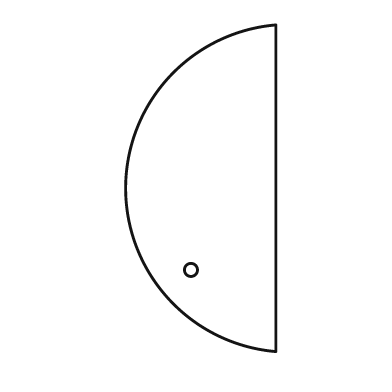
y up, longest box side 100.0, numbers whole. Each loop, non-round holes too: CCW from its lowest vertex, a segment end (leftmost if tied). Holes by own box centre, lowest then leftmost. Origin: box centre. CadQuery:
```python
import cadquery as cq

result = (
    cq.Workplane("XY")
    .moveTo(23.0, -50.0)
    .lineTo(23.0, 50.0)
    .threePointArc((-23.0, 0.0), (23.0, -50.0))
    .close()
    .moveTo(-3.0, -25.0)
    .circle(2.0)
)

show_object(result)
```